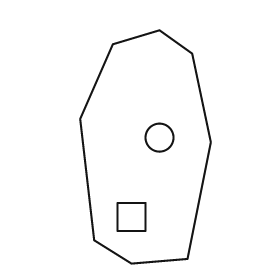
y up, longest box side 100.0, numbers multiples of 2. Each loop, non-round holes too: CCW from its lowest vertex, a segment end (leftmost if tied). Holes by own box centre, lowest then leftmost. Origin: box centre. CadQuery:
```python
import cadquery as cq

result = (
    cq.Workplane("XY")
    .moveTo(-6.0, -50.0)
    .lineTo(18.0, -48.0)
    .lineTo(28.0, 2.0)
    .lineTo(20.0, 40.0)
    .lineTo(6.0, 50.0)
    .lineTo(-14.0, 44.0)
    .lineTo(-28.0, 12.0)
    .lineTo(-22.0, -40.0)
    .close()
    .moveTo(-12.0, -36.0)
    .lineTo(0.0, -36.0)
    .lineTo(0.0, -24.0)
    .lineTo(-12.0, -24.0)
    .close()
    .moveTo(6.0, 4.0)
    .circle(6.0)
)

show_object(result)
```